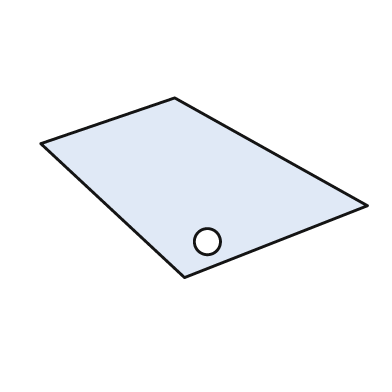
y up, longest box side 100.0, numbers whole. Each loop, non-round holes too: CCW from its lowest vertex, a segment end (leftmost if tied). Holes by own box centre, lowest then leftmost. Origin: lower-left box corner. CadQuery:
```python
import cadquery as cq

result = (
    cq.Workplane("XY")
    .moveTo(44.0, 0.0)
    .lineTo(100.0, 22.0)
    .lineTo(41.0, 55.0)
    .lineTo(0.0, 41.0)
    .close()
    .moveTo(51.0, 11.0)
    .circle(4.0)
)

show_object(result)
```